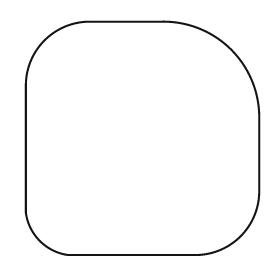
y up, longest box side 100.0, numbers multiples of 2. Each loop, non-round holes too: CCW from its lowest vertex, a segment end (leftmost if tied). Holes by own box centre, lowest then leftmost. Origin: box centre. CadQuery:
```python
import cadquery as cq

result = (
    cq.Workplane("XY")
    .moveTo(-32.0, -50.0)
    .lineTo(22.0, -50.0)
    .threePointArc((42.0, -42.0), (50.0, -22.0))
    .lineTo(50.0, 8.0)
    .threePointArc((38.0, 38.0), (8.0, 50.0))
    .lineTo(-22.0, 50.0)
    .threePointArc((-42.0, 42.0), (-50.0, 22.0))
    .lineTo(-50.0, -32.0)
    .threePointArc((-44.0, -44.0), (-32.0, -50.0))
    .close()
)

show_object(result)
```